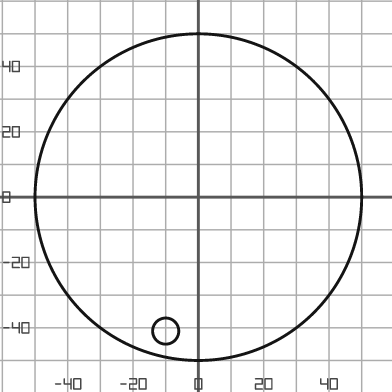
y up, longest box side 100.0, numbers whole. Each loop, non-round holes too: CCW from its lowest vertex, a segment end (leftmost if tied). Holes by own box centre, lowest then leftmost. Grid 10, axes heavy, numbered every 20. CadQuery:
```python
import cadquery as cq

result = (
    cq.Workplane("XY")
    .moveTo(0.0, 0.0)
    .circle(50.0)
    .moveTo(-10.0, -41.0)
    .circle(4.0)
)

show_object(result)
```